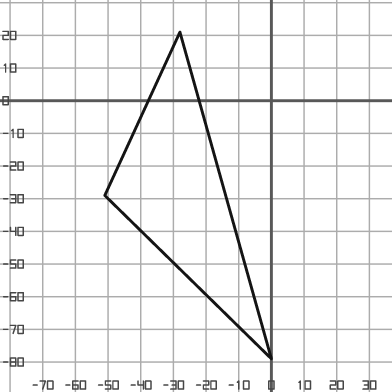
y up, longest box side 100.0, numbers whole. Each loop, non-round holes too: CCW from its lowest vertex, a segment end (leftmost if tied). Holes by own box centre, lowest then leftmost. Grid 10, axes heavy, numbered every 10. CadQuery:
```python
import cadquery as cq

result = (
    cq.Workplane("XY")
    .moveTo(0.0, -79.0)
    .lineTo(-28.0, 21.0)
    .lineTo(-51.0, -29.0)
    .close()
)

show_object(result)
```